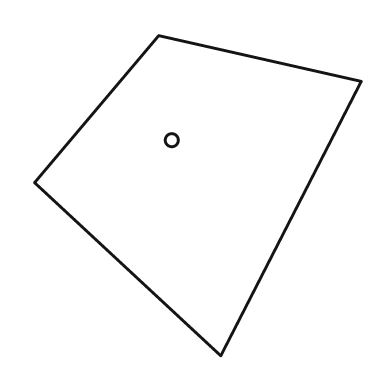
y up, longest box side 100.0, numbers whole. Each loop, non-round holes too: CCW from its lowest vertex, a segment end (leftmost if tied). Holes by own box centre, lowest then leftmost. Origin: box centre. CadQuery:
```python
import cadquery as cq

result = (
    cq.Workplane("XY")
    .moveTo(7.0, -49.0)
    .lineTo(50.0, 35.0)
    .lineTo(-12.0, 49.0)
    .lineTo(-50.0, 4.0)
    .close()
    .moveTo(-8.0, 17.0)
    .circle(2.0)
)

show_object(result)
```